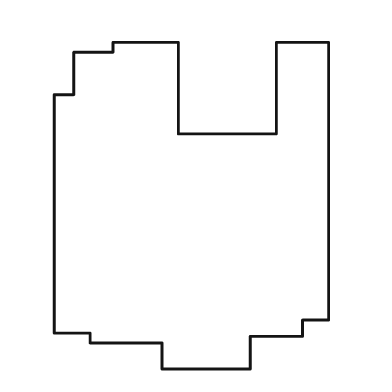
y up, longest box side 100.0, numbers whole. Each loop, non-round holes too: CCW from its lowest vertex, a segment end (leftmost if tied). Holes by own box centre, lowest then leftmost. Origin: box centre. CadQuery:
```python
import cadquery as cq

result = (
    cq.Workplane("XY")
    .moveTo(-9.0, -50.0)
    .lineTo(18.0, -50.0)
    .lineTo(18.0, -40.0)
    .lineTo(34.0, -40.0)
    .lineTo(34.0, -35.0)
    .lineTo(42.0, -35.0)
    .lineTo(42.0, 50.0)
    .lineTo(26.0, 50.0)
    .lineTo(26.0, 22.0)
    .lineTo(-4.0, 22.0)
    .lineTo(-4.0, 50.0)
    .lineTo(-24.0, 50.0)
    .lineTo(-24.0, 47.0)
    .lineTo(-36.0, 47.0)
    .lineTo(-36.0, 34.0)
    .lineTo(-42.0, 34.0)
    .lineTo(-42.0, -39.0)
    .lineTo(-31.0, -39.0)
    .lineTo(-31.0, -42.0)
    .lineTo(-9.0, -42.0)
    .close()
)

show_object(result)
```